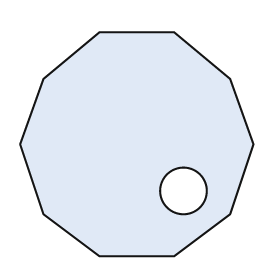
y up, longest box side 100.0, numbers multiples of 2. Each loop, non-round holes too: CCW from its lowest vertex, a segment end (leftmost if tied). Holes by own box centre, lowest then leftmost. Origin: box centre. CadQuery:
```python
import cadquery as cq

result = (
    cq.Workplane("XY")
    .moveTo(-16.0, -48.0)
    .lineTo(16.0, -48.0)
    .lineTo(40.0, -30.0)
    .lineTo(50.0, 0.0)
    .lineTo(40.0, 28.0)
    .lineTo(16.0, 48.0)
    .lineTo(-16.0, 48.0)
    .lineTo(-40.0, 28.0)
    .lineTo(-50.0, 0.0)
    .lineTo(-40.0, -30.0)
    .close()
    .moveTo(20.0, -20.0)
    .circle(10.0)
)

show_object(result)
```